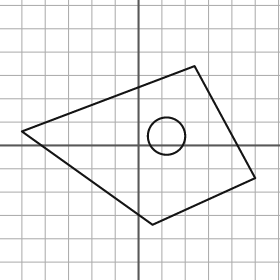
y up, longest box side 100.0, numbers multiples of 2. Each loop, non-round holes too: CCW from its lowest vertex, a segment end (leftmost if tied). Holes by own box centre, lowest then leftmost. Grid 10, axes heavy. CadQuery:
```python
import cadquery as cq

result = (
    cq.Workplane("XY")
    .moveTo(6.0, -34.0)
    .lineTo(50.0, -14.0)
    .lineTo(24.0, 34.0)
    .lineTo(-50.0, 6.0)
    .close()
    .moveTo(12.0, 4.0)
    .circle(8.0)
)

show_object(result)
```